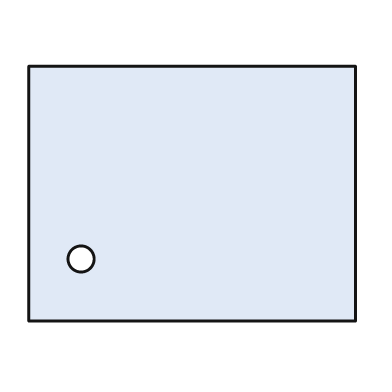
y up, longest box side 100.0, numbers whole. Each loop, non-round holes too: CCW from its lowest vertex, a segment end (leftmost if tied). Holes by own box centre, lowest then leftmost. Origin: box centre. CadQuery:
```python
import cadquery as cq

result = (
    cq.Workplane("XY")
    .moveTo(-50.0, -39.0)
    .lineTo(50.0, -39.0)
    .lineTo(50.0, 39.0)
    .lineTo(-50.0, 39.0)
    .close()
    .moveTo(-34.0, -20.0)
    .circle(4.0)
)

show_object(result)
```